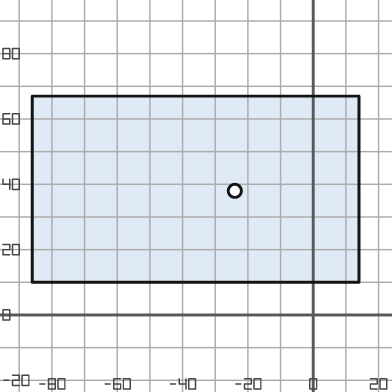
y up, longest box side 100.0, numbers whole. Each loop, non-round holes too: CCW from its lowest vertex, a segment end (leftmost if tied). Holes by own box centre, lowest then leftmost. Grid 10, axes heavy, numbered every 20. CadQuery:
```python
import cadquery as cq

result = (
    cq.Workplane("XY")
    .moveTo(-86.0, 10.0)
    .lineTo(14.0, 10.0)
    .lineTo(14.0, 67.0)
    .lineTo(-86.0, 67.0)
    .close()
    .moveTo(-24.0, 38.0)
    .circle(2.0)
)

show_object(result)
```